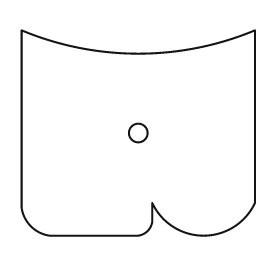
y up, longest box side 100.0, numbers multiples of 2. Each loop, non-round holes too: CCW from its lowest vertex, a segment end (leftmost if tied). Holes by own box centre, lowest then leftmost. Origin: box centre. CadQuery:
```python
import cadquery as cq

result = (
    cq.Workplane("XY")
    .moveTo(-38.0, -44.0)
    .lineTo(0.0, -44.0)
    .threePointArc((4.0, -42.0), (6.0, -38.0))
    .lineTo(6.0, -30.0)
    .threePointArc((28.0, -44.0), (50.0, -30.0))
    .lineTo(50.0, 44.0)
    .threePointArc((0.0, 34.0), (-50.0, 44.0))
    .lineTo(-50.0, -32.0)
    .threePointArc((-46.0, -40.0), (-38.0, -44.0))
    .close()
    .moveTo(0.0, 0.0)
    .circle(4.0)
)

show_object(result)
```